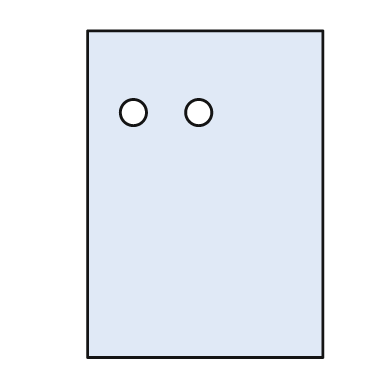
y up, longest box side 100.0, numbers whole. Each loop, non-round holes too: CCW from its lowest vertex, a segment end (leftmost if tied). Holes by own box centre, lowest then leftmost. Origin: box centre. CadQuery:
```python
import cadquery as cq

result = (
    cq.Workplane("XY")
    .moveTo(-36.0, -50.0)
    .lineTo(36.0, -50.0)
    .lineTo(36.0, 50.0)
    .lineTo(-36.0, 50.0)
    .close()
    .moveTo(-22.0, 25.0)
    .circle(4.0)
    .moveTo(-2.0, 25.0)
    .circle(4.0)
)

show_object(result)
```